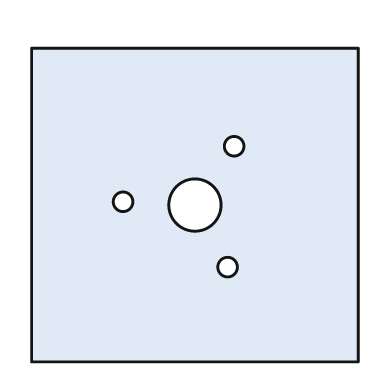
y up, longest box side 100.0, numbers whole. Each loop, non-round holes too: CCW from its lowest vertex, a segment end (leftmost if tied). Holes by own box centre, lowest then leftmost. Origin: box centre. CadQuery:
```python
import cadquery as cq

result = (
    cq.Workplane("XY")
    .moveTo(-50.0, -48.0)
    .lineTo(50.0, -48.0)
    .lineTo(50.0, 48.0)
    .lineTo(-50.0, 48.0)
    .close()
    .moveTo(10.0, -19.0)
    .circle(3.0)
    .moveTo(0.0, 0.0)
    .circle(8.0)
    .moveTo(-22.0, 1.0)
    .circle(3.0)
    .moveTo(12.0, 18.0)
    .circle(3.0)
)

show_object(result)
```